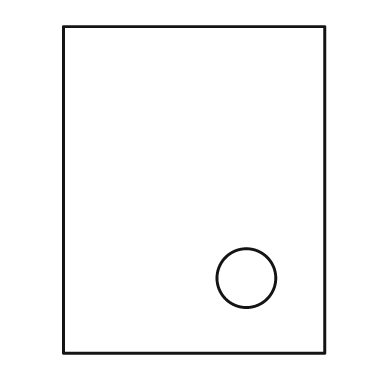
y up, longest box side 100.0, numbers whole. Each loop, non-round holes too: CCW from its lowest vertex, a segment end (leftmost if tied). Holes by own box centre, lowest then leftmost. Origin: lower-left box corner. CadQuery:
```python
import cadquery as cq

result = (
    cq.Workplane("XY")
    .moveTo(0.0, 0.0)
    .lineTo(80.0, 0.0)
    .lineTo(80.0, 100.0)
    .lineTo(0.0, 100.0)
    .close()
    .moveTo(56.0, 23.0)
    .circle(9.0)
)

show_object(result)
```